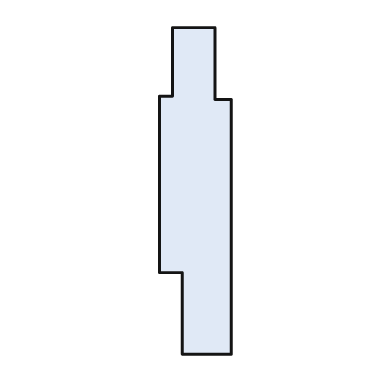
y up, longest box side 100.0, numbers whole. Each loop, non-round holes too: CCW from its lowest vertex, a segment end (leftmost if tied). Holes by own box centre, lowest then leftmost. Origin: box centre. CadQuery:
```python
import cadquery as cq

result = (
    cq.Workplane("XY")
    .moveTo(-4.0, -50.0)
    .lineTo(11.0, -50.0)
    .lineTo(11.0, 28.0)
    .lineTo(6.0, 28.0)
    .lineTo(6.0, 50.0)
    .lineTo(-7.0, 50.0)
    .lineTo(-7.0, 29.0)
    .lineTo(-11.0, 29.0)
    .lineTo(-11.0, -25.0)
    .lineTo(-4.0, -25.0)
    .close()
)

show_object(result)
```